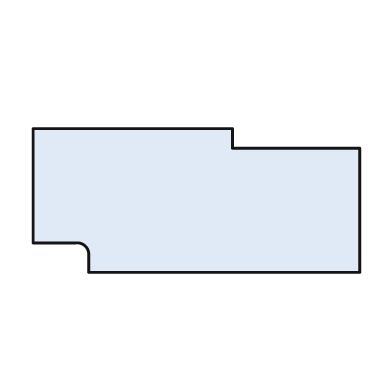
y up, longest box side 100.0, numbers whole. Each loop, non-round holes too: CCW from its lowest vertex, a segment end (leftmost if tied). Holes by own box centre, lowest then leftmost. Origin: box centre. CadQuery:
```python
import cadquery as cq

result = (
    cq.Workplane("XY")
    .moveTo(-33.0, -22.0)
    .lineTo(50.0, -22.0)
    .lineTo(50.0, 16.0)
    .lineTo(11.0, 16.0)
    .lineTo(11.0, 22.0)
    .lineTo(-50.0, 22.0)
    .lineTo(-50.0, -13.0)
    .lineTo(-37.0, -13.0)
    .threePointArc((-34.0, -14.0), (-33.0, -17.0))
    .close()
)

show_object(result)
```